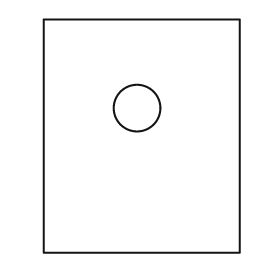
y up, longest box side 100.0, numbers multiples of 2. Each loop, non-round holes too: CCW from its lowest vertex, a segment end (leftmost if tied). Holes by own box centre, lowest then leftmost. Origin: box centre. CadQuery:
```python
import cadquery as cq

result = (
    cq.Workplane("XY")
    .moveTo(-42.0, -50.0)
    .lineTo(42.0, -50.0)
    .lineTo(42.0, 50.0)
    .lineTo(-42.0, 50.0)
    .close()
    .moveTo(-2.0, 12.0)
    .circle(10.0)
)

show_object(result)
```